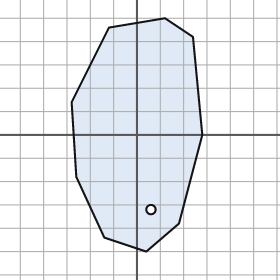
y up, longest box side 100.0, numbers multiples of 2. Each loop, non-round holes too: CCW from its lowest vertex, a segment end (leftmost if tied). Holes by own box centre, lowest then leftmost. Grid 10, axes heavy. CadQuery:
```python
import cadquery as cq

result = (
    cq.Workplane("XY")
    .moveTo(4.0, -50.0)
    .lineTo(18.0, -38.0)
    .lineTo(28.0, 0.0)
    .lineTo(24.0, 42.0)
    .lineTo(12.0, 50.0)
    .lineTo(-12.0, 46.0)
    .lineTo(-28.0, 14.0)
    .lineTo(-26.0, -18.0)
    .lineTo(-14.0, -44.0)
    .close()
    .moveTo(6.0, -32.0)
    .circle(2.0)
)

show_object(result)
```